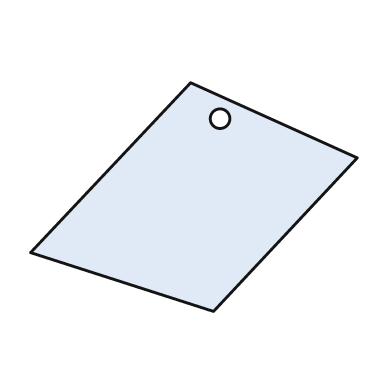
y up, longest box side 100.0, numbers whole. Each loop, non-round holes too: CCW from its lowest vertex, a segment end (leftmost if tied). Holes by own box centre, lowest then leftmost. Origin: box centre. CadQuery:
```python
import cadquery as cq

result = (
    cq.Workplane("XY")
    .moveTo(6.0, -35.0)
    .lineTo(50.0, 12.0)
    .lineTo(-1.0, 35.0)
    .lineTo(-50.0, -17.0)
    .close()
    .moveTo(8.0, 24.0)
    .circle(3.0)
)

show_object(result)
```